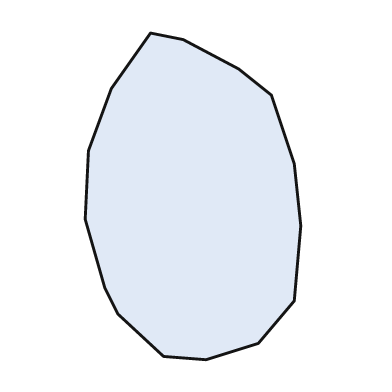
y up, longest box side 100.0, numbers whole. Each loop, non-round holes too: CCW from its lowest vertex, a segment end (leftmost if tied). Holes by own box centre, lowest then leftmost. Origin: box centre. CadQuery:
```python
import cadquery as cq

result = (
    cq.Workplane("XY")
    .moveTo(4.0, -50.0)
    .lineTo(20.0, -45.0)
    .lineTo(31.0, -32.0)
    .lineTo(33.0, -9.0)
    .lineTo(31.0, 10.0)
    .lineTo(24.0, 31.0)
    .lineTo(14.0, 39.0)
    .lineTo(-3.0, 48.0)
    .lineTo(-13.0, 50.0)
    .lineTo(-25.0, 33.0)
    .lineTo(-32.0, 14.0)
    .lineTo(-33.0, -7.0)
    .lineTo(-27.0, -28.0)
    .lineTo(-23.0, -36.0)
    .lineTo(-9.0, -49.0)
    .close()
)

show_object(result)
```